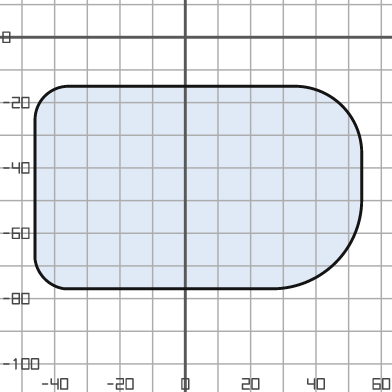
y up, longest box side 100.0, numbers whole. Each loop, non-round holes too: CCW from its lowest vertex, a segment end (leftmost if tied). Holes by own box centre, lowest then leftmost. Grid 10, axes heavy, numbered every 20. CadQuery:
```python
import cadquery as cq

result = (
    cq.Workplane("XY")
    .moveTo(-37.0, -77.0)
    .lineTo(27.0, -77.0)
    .threePointArc((46.0, -69.0), (54.0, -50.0))
    .lineTo(54.0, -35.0)
    .threePointArc((48.0, -21.0), (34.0, -15.0))
    .lineTo(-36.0, -15.0)
    .threePointArc((-43.0, -18.0), (-46.0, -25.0))
    .lineTo(-46.0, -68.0)
    .threePointArc((-43.0, -74.0), (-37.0, -77.0))
    .close()
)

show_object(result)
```